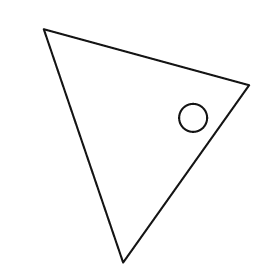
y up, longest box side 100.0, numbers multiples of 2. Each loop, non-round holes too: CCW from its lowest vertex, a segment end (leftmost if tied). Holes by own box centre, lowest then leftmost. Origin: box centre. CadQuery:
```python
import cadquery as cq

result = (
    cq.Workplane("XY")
    .moveTo(-10.0, -50.0)
    .lineTo(44.0, 26.0)
    .lineTo(-44.0, 50.0)
    .close()
    .moveTo(20.0, 12.0)
    .circle(6.0)
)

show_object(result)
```